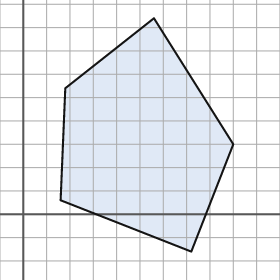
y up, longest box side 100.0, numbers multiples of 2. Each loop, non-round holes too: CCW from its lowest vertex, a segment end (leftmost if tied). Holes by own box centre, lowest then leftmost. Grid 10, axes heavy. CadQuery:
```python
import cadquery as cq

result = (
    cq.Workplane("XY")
    .moveTo(72.0, -16.0)
    .lineTo(90.0, 30.0)
    .lineTo(56.0, 84.0)
    .lineTo(18.0, 54.0)
    .lineTo(16.0, 6.0)
    .close()
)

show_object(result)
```